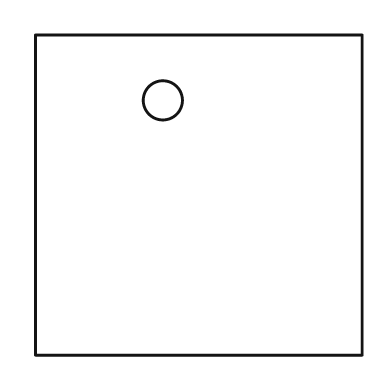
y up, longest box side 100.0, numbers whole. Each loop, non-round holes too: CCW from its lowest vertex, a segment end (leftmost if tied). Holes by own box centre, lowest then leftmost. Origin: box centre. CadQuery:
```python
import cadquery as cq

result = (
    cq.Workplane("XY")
    .moveTo(-50.0, -49.0)
    .lineTo(50.0, -49.0)
    .lineTo(50.0, 49.0)
    .lineTo(-50.0, 49.0)
    .close()
    .moveTo(-11.0, 29.0)
    .circle(6.0)
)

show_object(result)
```